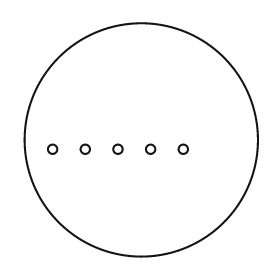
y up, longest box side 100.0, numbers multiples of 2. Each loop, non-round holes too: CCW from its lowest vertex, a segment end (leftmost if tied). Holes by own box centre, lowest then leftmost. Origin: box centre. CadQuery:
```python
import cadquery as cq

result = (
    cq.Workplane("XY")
    .moveTo(0.0, 0.0)
    .circle(50.0)
    .moveTo(-38.0, -4.0)
    .circle(2.0)
    .moveTo(-24.0, -4.0)
    .circle(2.0)
    .moveTo(-10.0, -4.0)
    .circle(2.0)
    .moveTo(4.0, -4.0)
    .circle(2.0)
    .moveTo(18.0, -4.0)
    .circle(2.0)
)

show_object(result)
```